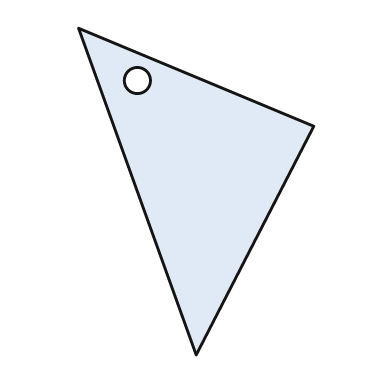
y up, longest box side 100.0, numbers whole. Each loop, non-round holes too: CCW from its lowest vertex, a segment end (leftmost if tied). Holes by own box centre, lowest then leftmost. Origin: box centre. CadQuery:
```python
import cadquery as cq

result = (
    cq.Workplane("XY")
    .moveTo(0.0, -50.0)
    .lineTo(36.0, 20.0)
    .lineTo(-36.0, 50.0)
    .close()
    .moveTo(-18.0, 34.0)
    .circle(4.0)
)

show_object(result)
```